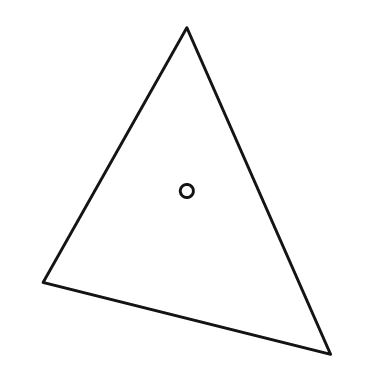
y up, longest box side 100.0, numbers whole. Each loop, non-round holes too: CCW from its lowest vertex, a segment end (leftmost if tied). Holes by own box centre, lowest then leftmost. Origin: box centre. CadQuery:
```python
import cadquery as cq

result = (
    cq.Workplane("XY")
    .moveTo(44.0, -50.0)
    .lineTo(0.0, 50.0)
    .lineTo(-44.0, -28.0)
    .close()
    .moveTo(0.0, 0.0)
    .circle(2.0)
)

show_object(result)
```